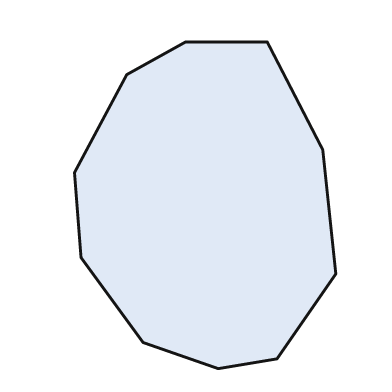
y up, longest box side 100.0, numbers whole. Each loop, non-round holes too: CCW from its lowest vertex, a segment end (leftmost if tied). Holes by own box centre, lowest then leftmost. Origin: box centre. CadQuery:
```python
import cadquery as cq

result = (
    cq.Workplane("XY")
    .moveTo(4.0, -50.0)
    .lineTo(22.0, -47.0)
    .lineTo(40.0, -21.0)
    .lineTo(36.0, 17.0)
    .lineTo(19.0, 50.0)
    .lineTo(-6.0, 50.0)
    .lineTo(-24.0, 40.0)
    .lineTo(-40.0, 10.0)
    .lineTo(-38.0, -16.0)
    .lineTo(-19.0, -42.0)
    .close()
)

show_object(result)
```